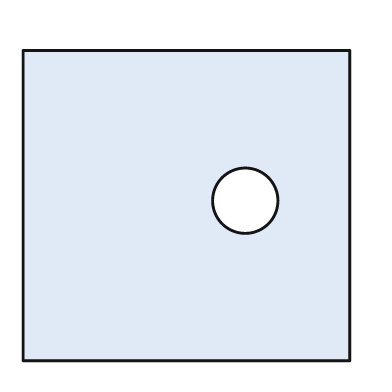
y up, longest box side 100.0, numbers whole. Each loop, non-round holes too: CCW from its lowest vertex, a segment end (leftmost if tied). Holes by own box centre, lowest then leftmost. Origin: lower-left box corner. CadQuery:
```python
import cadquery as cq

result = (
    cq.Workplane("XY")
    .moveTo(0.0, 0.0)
    .lineTo(100.0, 0.0)
    .lineTo(100.0, 95.0)
    .lineTo(0.0, 95.0)
    .close()
    .moveTo(68.0, 49.0)
    .circle(10.0)
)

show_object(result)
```